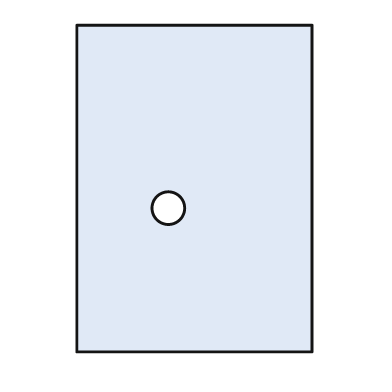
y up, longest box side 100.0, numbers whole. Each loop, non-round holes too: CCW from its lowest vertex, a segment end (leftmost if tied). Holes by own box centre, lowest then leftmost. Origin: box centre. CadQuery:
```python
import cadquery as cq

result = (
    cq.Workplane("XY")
    .moveTo(-36.0, -50.0)
    .lineTo(36.0, -50.0)
    .lineTo(36.0, 50.0)
    .lineTo(-36.0, 50.0)
    .close()
    .moveTo(-8.0, -6.0)
    .circle(5.0)
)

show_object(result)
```